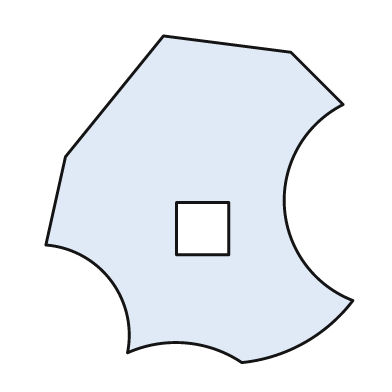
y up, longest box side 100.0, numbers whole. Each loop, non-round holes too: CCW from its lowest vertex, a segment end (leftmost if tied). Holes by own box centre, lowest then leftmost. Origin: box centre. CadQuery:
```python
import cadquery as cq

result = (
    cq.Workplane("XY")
    .moveTo(13.0, -50.0)
    .threePointArc((32.0, -44.0), (47.0, -31.0))
    .threePointArc((26.0, -2.0), (44.0, 29.0))
    .lineTo(28.0, 45.0)
    .lineTo(-11.0, 50.0)
    .lineTo(-41.0, 13.0)
    .lineTo(-47.0, -14.0)
    .threePointArc((-27.0, -25.0), (-22.0, -47.0))
    .threePointArc((-4.0, -44.0), (13.0, -50.0))
    .close()
    .moveTo(-7.0, -17.0)
    .lineTo(9.0, -17.0)
    .lineTo(9.0, -1.0)
    .lineTo(-7.0, -1.0)
    .close()
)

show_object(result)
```